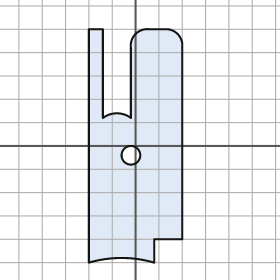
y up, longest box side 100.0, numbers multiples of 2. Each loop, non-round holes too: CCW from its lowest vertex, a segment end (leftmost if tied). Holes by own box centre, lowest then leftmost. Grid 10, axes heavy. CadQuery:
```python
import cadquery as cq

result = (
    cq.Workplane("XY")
    .moveTo(-20.0, -50.0)
    .threePointArc((-6.0, -48.0), (8.0, -50.0))
    .lineTo(8.0, -40.0)
    .lineTo(20.0, -40.0)
    .lineTo(20.0, 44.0)
    .threePointArc((18.0, 48.0), (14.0, 50.0))
    .lineTo(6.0, 50.0)
    .threePointArc((0.0, 48.0), (-2.0, 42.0))
    .lineTo(-2.0, 12.0)
    .threePointArc((-8.0, 14.0), (-14.0, 12.0))
    .lineTo(-14.0, 50.0)
    .lineTo(-20.0, 50.0)
    .close()
    .moveTo(-2.0, -4.0)
    .circle(4.0)
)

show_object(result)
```